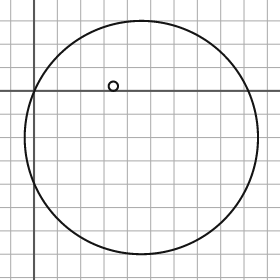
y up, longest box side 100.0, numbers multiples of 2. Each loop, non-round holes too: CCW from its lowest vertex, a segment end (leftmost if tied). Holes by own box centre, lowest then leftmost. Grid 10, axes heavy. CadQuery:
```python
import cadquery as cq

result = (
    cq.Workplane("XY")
    .moveTo(46.0, -20.0)
    .circle(50.0)
    .moveTo(34.0, 2.0)
    .circle(2.0)
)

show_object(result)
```